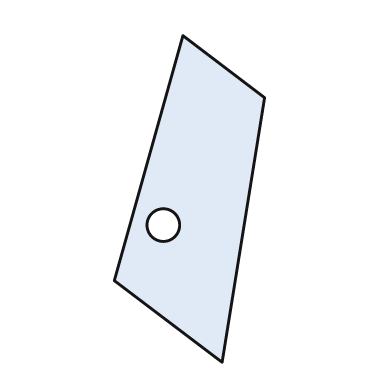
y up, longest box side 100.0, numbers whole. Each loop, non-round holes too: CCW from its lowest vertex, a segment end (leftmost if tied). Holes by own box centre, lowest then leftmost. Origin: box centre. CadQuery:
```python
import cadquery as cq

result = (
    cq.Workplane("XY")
    .moveTo(10.0, -50.0)
    .lineTo(23.0, 31.0)
    .lineTo(-2.0, 50.0)
    .lineTo(-23.0, -25.0)
    .close()
    .moveTo(-8.0, -8.0)
    .circle(5.0)
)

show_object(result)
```